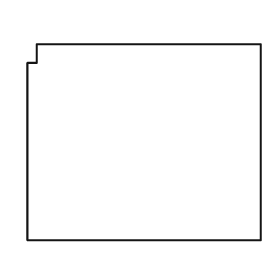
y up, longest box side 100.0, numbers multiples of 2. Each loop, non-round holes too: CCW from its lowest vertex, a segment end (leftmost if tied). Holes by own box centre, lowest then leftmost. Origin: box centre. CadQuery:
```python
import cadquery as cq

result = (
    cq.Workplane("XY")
    .moveTo(-50.0, -42.0)
    .lineTo(50.0, -42.0)
    .lineTo(50.0, 42.0)
    .lineTo(-46.0, 42.0)
    .lineTo(-46.0, 34.0)
    .lineTo(-50.0, 34.0)
    .close()
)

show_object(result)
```